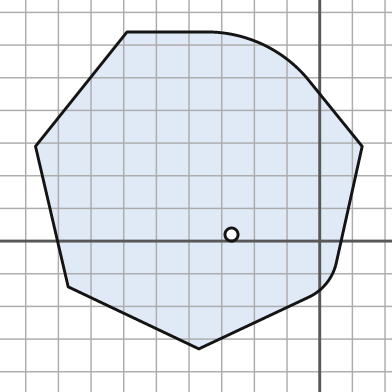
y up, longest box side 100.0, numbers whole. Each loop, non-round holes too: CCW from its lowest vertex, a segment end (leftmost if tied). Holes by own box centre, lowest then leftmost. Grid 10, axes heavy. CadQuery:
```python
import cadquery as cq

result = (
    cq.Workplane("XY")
    .moveTo(-37.0, -33.0)
    .lineTo(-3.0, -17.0)
    .threePointArc((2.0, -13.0), (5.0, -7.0))
    .lineTo(13.0, 29.0)
    .lineTo(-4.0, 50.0)
    .threePointArc((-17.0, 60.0), (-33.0, 64.0))
    .lineTo(-59.0, 64.0)
    .lineTo(-87.0, 29.0)
    .lineTo(-77.0, -14.0)
    .close()
    .moveTo(-27.0, 2.0)
    .circle(2.0)
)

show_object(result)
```